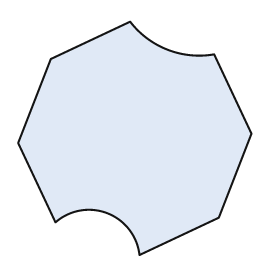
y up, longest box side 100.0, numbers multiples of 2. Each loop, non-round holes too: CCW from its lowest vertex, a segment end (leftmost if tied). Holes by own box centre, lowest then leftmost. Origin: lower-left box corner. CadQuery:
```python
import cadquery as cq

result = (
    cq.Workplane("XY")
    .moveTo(52.0, 0.0)
    .lineTo(86.0, 16.0)
    .lineTo(100.0, 52.0)
    .lineTo(84.0, 86.0)
    .threePointArc((64.0, 88.0), (48.0, 100.0))
    .lineTo(14.0, 84.0)
    .lineTo(0.0, 48.0)
    .lineTo(16.0, 14.0)
    .threePointArc((38.0, 18.0), (52.0, 0.0))
    .close()
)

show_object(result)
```